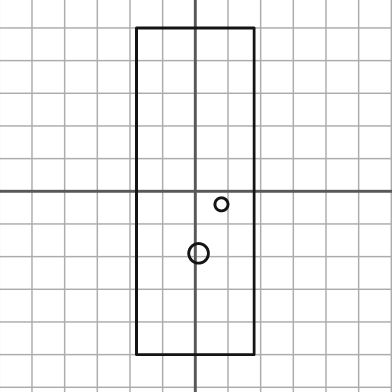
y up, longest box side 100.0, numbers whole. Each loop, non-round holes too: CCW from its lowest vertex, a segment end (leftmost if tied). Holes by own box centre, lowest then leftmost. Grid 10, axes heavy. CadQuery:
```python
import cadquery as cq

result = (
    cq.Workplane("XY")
    .moveTo(-18.0, -50.0)
    .lineTo(18.0, -50.0)
    .lineTo(18.0, 50.0)
    .lineTo(-18.0, 50.0)
    .close()
    .moveTo(1.0, -19.0)
    .circle(3.0)
    .moveTo(8.0, -4.0)
    .circle(2.0)
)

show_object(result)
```